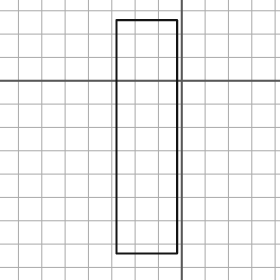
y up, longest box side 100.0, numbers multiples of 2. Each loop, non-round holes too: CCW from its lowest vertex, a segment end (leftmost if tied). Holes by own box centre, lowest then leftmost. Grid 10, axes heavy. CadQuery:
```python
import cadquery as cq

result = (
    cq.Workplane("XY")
    .moveTo(-28.0, -74.0)
    .lineTo(-2.0, -74.0)
    .lineTo(-2.0, 26.0)
    .lineTo(-28.0, 26.0)
    .close()
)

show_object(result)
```